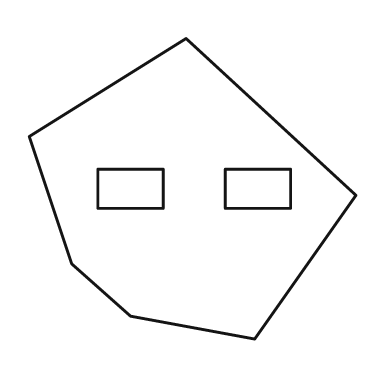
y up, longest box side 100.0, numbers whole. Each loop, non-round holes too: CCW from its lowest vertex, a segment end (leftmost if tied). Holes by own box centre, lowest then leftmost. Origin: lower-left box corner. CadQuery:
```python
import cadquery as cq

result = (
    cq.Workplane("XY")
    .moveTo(69.0, 0.0)
    .lineTo(100.0, 44.0)
    .lineTo(48.0, 92.0)
    .lineTo(0.0, 62.0)
    .lineTo(13.0, 23.0)
    .lineTo(31.0, 7.0)
    .close()
    .moveTo(21.0, 40.0)
    .lineTo(41.0, 40.0)
    .lineTo(41.0, 52.0)
    .lineTo(21.0, 52.0)
    .close()
    .moveTo(60.0, 40.0)
    .lineTo(80.0, 40.0)
    .lineTo(80.0, 52.0)
    .lineTo(60.0, 52.0)
    .close()
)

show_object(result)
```